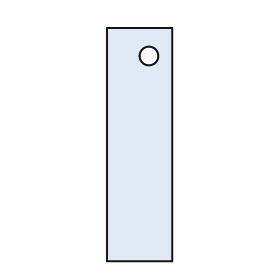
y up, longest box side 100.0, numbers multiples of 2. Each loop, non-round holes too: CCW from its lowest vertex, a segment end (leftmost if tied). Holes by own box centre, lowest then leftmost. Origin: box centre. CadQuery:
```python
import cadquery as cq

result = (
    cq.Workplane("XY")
    .moveTo(-14.0, -50.0)
    .lineTo(14.0, -50.0)
    .lineTo(14.0, 50.0)
    .lineTo(-14.0, 50.0)
    .close()
    .moveTo(4.0, 38.0)
    .circle(4.0)
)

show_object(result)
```